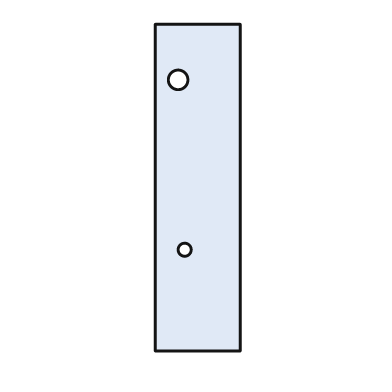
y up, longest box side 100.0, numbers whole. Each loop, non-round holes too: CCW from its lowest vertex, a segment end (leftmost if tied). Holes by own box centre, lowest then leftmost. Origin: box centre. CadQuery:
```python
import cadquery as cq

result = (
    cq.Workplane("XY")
    .moveTo(-13.0, -50.0)
    .lineTo(13.0, -50.0)
    .lineTo(13.0, 50.0)
    .lineTo(-13.0, 50.0)
    .close()
    .moveTo(-4.0, -19.0)
    .circle(2.0)
    .moveTo(-6.0, 33.0)
    .circle(3.0)
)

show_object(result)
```